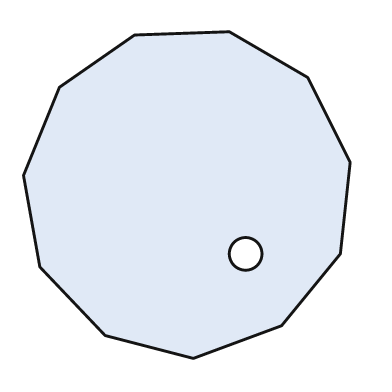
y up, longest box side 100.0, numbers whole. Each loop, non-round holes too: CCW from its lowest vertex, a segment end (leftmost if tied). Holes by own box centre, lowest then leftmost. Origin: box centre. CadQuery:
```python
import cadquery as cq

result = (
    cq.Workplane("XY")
    .moveTo(2.0, -50.0)
    .lineTo(29.0, -40.0)
    .lineTo(47.0, -18.0)
    .lineTo(50.0, 10.0)
    .lineTo(37.0, 36.0)
    .lineTo(13.0, 50.0)
    .lineTo(-16.0, 49.0)
    .lineTo(-39.0, 33.0)
    .lineTo(-50.0, 6.0)
    .lineTo(-45.0, -22.0)
    .lineTo(-25.0, -43.0)
    .close()
    .moveTo(18.0, -18.0)
    .circle(5.0)
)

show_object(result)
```